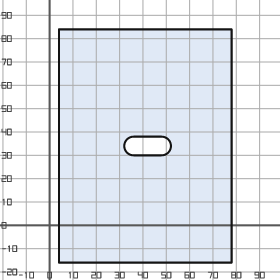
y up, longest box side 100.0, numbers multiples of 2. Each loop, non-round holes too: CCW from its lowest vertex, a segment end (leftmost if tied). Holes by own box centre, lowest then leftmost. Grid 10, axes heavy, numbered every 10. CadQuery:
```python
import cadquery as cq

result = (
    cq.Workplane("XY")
    .moveTo(4.0, -16.0)
    .lineTo(78.0, -16.0)
    .lineTo(78.0, 84.0)
    .lineTo(4.0, 84.0)
    .close()
    .moveTo(36.0, 30.0)
    .lineTo(48.0, 30.0)
    .threePointArc((52.0, 34.0), (48.0, 38.0))
    .lineTo(36.0, 38.0)
    .threePointArc((32.0, 34.0), (36.0, 30.0))
    .close()
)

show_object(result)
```